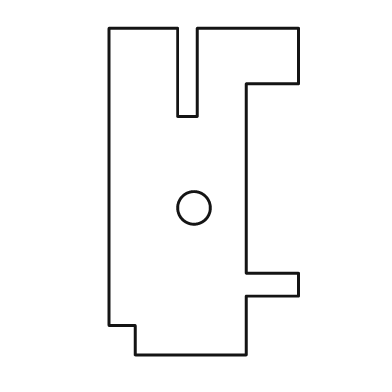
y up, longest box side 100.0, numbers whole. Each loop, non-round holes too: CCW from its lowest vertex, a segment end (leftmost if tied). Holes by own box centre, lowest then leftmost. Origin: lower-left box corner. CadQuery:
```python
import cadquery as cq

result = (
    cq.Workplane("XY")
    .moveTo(8.0, 0.0)
    .lineTo(42.0, 0.0)
    .lineTo(42.0, 18.0)
    .lineTo(58.0, 18.0)
    .lineTo(58.0, 25.0)
    .lineTo(42.0, 25.0)
    .lineTo(42.0, 83.0)
    .lineTo(58.0, 83.0)
    .lineTo(58.0, 100.0)
    .lineTo(27.0, 100.0)
    .lineTo(27.0, 73.0)
    .lineTo(21.0, 73.0)
    .lineTo(21.0, 100.0)
    .lineTo(0.0, 100.0)
    .lineTo(0.0, 9.0)
    .lineTo(8.0, 9.0)
    .close()
    .moveTo(26.0, 45.0)
    .circle(5.0)
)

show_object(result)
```